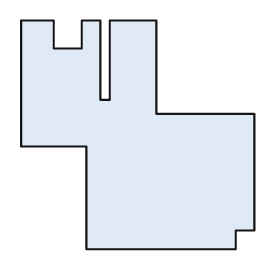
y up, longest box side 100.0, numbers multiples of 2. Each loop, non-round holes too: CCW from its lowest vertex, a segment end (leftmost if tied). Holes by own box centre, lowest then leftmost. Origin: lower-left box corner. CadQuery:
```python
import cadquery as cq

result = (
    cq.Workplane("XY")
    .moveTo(28.0, 0.0)
    .lineTo(92.0, 0.0)
    .lineTo(92.0, 8.0)
    .lineTo(100.0, 8.0)
    .lineTo(100.0, 58.0)
    .lineTo(58.0, 58.0)
    .lineTo(58.0, 98.0)
    .lineTo(38.0, 98.0)
    .lineTo(38.0, 64.0)
    .lineTo(34.0, 64.0)
    .lineTo(34.0, 98.0)
    .lineTo(26.0, 98.0)
    .lineTo(26.0, 86.0)
    .lineTo(14.0, 86.0)
    .lineTo(14.0, 98.0)
    .lineTo(0.0, 98.0)
    .lineTo(0.0, 44.0)
    .lineTo(28.0, 44.0)
    .close()
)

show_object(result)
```